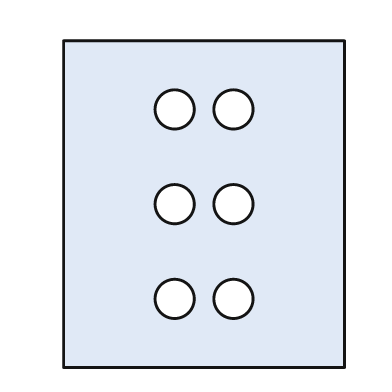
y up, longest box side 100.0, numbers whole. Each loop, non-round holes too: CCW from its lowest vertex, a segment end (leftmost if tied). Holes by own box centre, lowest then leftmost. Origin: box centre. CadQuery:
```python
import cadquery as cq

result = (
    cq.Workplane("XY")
    .moveTo(-43.0, -50.0)
    .lineTo(43.0, -50.0)
    .lineTo(43.0, 50.0)
    .lineTo(-43.0, 50.0)
    .close()
    .moveTo(-9.0, -29.0)
    .circle(6.0)
    .moveTo(9.0, -29.0)
    .circle(6.0)
    .moveTo(-9.0, 0.0)
    .circle(6.0)
    .moveTo(9.0, 0.0)
    .circle(6.0)
    .moveTo(-9.0, 29.0)
    .circle(6.0)
    .moveTo(9.0, 29.0)
    .circle(6.0)
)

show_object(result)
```